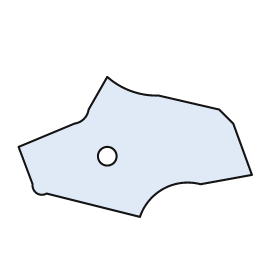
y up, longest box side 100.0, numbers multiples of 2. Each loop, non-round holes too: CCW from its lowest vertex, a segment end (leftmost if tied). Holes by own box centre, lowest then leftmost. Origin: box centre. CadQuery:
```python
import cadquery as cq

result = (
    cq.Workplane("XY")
    .moveTo(2.0, -30.0)
    .threePointArc((12.0, -18.0), (28.0, -16.0))
    .lineTo(50.0, -12.0)
    .lineTo(42.0, 10.0)
    .lineTo(36.0, 16.0)
    .lineTo(10.0, 22.0)
    .threePointArc((-2.0, 24.0), (-12.0, 30.0))
    .lineTo(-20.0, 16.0)
    .threePointArc((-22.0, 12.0), (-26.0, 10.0))
    .lineTo(-50.0, 0.0)
    .lineTo(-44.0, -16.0)
    .threePointArc((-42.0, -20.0), (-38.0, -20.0))
    .close()
    .moveTo(-12.0, -4.0)
    .circle(4.0)
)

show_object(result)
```